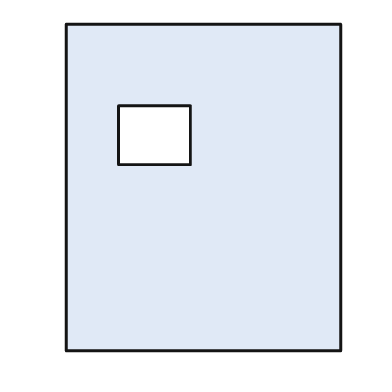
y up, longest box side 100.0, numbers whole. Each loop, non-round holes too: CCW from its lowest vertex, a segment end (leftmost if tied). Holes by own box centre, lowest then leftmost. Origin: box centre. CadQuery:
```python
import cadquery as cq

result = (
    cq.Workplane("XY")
    .moveTo(-42.0, -50.0)
    .lineTo(42.0, -50.0)
    .lineTo(42.0, 50.0)
    .lineTo(-42.0, 50.0)
    .close()
    .moveTo(-26.0, 7.0)
    .lineTo(-4.0, 7.0)
    .lineTo(-4.0, 25.0)
    .lineTo(-26.0, 25.0)
    .close()
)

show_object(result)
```